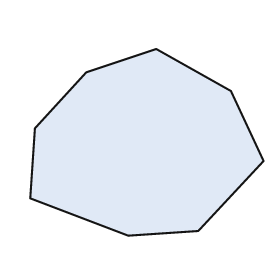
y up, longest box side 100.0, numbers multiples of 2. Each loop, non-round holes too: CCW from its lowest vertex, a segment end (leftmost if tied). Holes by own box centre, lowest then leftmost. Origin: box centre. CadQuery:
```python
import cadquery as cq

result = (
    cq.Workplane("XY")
    .moveTo(-8.0, -40.0)
    .lineTo(22.0, -38.0)
    .lineTo(50.0, -8.0)
    .lineTo(36.0, 22.0)
    .lineTo(4.0, 40.0)
    .lineTo(-26.0, 30.0)
    .lineTo(-48.0, 6.0)
    .lineTo(-50.0, -24.0)
    .close()
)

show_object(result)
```